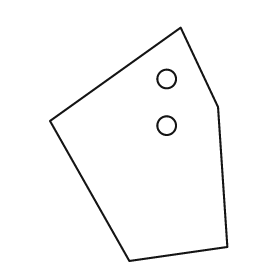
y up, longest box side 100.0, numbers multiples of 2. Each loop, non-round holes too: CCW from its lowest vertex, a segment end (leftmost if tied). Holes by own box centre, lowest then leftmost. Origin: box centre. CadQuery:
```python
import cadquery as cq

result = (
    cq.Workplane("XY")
    .moveTo(-4.0, -50.0)
    .lineTo(38.0, -44.0)
    .lineTo(34.0, 16.0)
    .lineTo(18.0, 50.0)
    .lineTo(-38.0, 10.0)
    .close()
    .moveTo(12.0, 8.0)
    .circle(4.0)
    .moveTo(12.0, 28.0)
    .circle(4.0)
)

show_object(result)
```